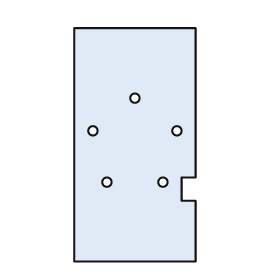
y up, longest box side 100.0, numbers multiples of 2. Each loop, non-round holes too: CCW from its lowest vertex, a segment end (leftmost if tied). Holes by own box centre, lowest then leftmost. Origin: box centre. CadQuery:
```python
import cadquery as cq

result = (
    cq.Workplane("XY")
    .moveTo(-26.0, -50.0)
    .lineTo(26.0, -50.0)
    .lineTo(26.0, -24.0)
    .lineTo(20.0, -24.0)
    .lineTo(20.0, -14.0)
    .lineTo(26.0, -14.0)
    .lineTo(26.0, 50.0)
    .lineTo(-26.0, 50.0)
    .close()
    .moveTo(-12.0, -16.0)
    .circle(2.0)
    .moveTo(12.0, -16.0)
    .circle(2.0)
    .moveTo(-18.0, 6.0)
    .circle(2.0)
    .moveTo(18.0, 6.0)
    .circle(2.0)
    .moveTo(0.0, 20.0)
    .circle(2.0)
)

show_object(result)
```